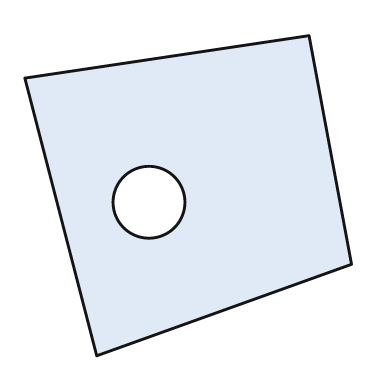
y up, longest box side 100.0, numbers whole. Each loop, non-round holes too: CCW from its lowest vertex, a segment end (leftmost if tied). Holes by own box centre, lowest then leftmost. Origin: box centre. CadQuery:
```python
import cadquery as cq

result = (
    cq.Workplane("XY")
    .moveTo(-28.0, -49.0)
    .lineTo(50.0, -21.0)
    .lineTo(37.0, 49.0)
    .lineTo(-50.0, 36.0)
    .close()
    .moveTo(-12.0, -2.0)
    .circle(11.0)
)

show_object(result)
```